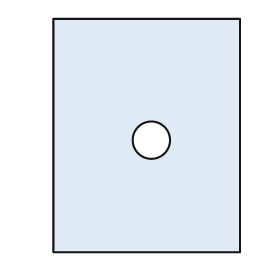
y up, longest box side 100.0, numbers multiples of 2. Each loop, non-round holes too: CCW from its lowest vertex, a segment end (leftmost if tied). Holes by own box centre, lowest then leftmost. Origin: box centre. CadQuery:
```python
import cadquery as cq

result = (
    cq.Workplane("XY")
    .moveTo(-40.0, -50.0)
    .lineTo(40.0, -50.0)
    .lineTo(40.0, 50.0)
    .lineTo(-40.0, 50.0)
    .close()
    .moveTo(2.0, -2.0)
    .circle(8.0)
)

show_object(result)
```